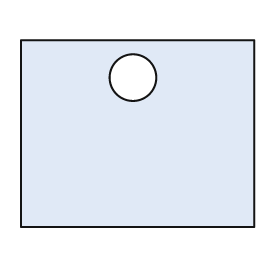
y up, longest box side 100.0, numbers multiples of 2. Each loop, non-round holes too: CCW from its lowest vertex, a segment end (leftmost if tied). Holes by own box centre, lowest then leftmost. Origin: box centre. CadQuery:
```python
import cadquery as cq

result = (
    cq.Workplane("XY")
    .moveTo(-50.0, -40.0)
    .lineTo(50.0, -40.0)
    .lineTo(50.0, 40.0)
    .lineTo(-50.0, 40.0)
    .close()
    .moveTo(-2.0, 24.0)
    .circle(10.0)
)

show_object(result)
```